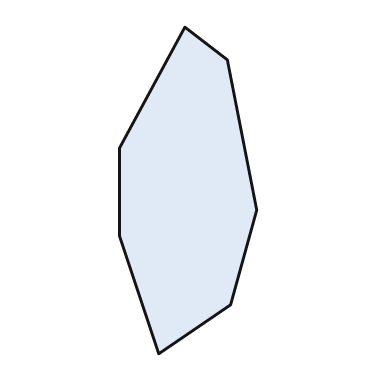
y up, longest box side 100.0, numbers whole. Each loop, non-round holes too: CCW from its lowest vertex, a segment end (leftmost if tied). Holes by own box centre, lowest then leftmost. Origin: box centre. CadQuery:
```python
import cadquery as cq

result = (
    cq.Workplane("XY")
    .moveTo(-9.0, -50.0)
    .lineTo(13.0, -35.0)
    .lineTo(21.0, -6.0)
    .lineTo(12.0, 40.0)
    .lineTo(-1.0, 50.0)
    .lineTo(-21.0, 13.0)
    .lineTo(-21.0, -14.0)
    .close()
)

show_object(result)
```